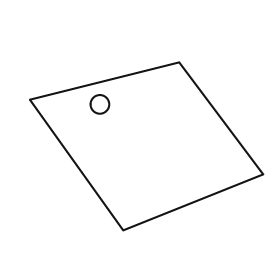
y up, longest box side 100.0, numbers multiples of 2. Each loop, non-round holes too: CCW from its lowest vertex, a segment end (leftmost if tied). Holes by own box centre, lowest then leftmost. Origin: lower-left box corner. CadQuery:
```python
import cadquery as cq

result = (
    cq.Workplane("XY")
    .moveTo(40.0, 0.0)
    .lineTo(100.0, 24.0)
    .lineTo(64.0, 72.0)
    .lineTo(0.0, 56.0)
    .close()
    .moveTo(30.0, 54.0)
    .circle(4.0)
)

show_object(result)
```